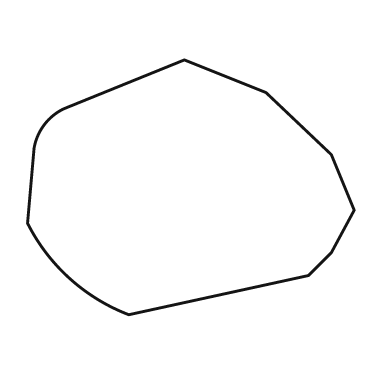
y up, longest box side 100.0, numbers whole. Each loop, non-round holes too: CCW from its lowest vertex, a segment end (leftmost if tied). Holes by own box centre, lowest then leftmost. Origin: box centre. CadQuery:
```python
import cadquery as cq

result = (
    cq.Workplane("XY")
    .moveTo(-19.0, -39.0)
    .lineTo(36.0, -27.0)
    .lineTo(43.0, -20.0)
    .lineTo(50.0, -7.0)
    .lineTo(43.0, 10.0)
    .lineTo(23.0, 29.0)
    .lineTo(-2.0, 39.0)
    .lineTo(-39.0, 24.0)
    .threePointArc((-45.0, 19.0), (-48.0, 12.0))
    .lineTo(-50.0, -11.0)
    .threePointArc((-37.0, -28.0), (-19.0, -39.0))
    .close()
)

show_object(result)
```